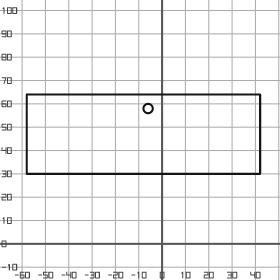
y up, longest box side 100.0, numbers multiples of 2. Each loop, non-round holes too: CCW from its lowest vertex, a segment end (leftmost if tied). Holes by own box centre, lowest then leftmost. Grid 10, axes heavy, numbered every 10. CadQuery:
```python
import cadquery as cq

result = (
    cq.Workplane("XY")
    .moveTo(-58.0, 30.0)
    .lineTo(42.0, 30.0)
    .lineTo(42.0, 64.0)
    .lineTo(-58.0, 64.0)
    .close()
    .moveTo(-6.0, 58.0)
    .circle(2.0)
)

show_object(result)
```